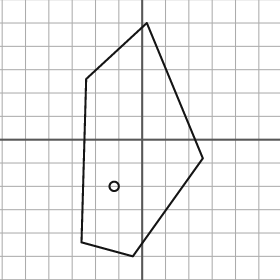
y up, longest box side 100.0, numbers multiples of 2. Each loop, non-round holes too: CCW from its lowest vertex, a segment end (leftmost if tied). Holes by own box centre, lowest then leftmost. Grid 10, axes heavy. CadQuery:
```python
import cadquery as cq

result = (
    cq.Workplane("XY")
    .moveTo(-4.0, -50.0)
    .lineTo(26.0, -8.0)
    .lineTo(2.0, 50.0)
    .lineTo(-24.0, 26.0)
    .lineTo(-26.0, -44.0)
    .close()
    .moveTo(-12.0, -20.0)
    .circle(2.0)
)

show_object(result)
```